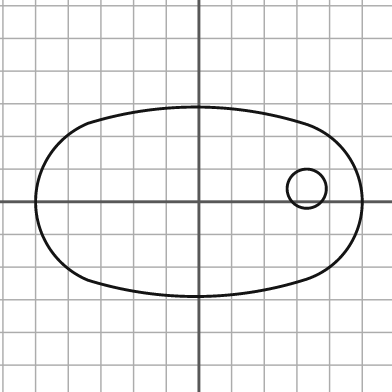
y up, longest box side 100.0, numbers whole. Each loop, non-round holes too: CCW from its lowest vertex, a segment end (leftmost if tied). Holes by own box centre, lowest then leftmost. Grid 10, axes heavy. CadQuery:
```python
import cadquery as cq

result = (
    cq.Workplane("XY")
    .moveTo(-34.0, -24.0)
    .threePointArc((-1.0, -29.0), (32.0, -24.0))
    .threePointArc((50.0, 0.0), (32.0, 24.0))
    .threePointArc((-1.0, 29.0), (-34.0, 24.0))
    .threePointArc((-50.0, 0.0), (-34.0, -24.0))
    .close()
    .moveTo(33.0, 4.0)
    .circle(6.0)
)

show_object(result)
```